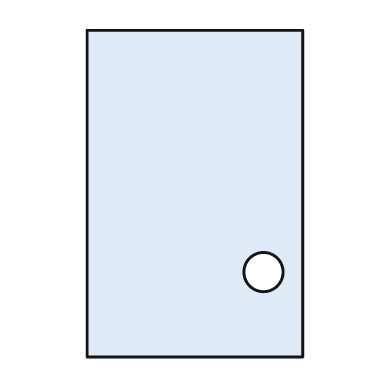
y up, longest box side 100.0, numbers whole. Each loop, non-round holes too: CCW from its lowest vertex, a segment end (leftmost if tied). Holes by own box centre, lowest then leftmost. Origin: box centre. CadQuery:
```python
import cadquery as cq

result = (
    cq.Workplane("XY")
    .moveTo(-33.0, -50.0)
    .lineTo(33.0, -50.0)
    .lineTo(33.0, 50.0)
    .lineTo(-33.0, 50.0)
    .close()
    .moveTo(21.0, -24.0)
    .circle(6.0)
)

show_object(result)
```